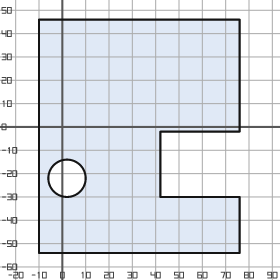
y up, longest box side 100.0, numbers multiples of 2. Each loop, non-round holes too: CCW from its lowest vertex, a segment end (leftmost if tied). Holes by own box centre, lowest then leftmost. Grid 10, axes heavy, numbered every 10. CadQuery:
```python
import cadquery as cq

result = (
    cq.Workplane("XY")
    .moveTo(-10.0, -54.0)
    .lineTo(76.0, -54.0)
    .lineTo(76.0, -30.0)
    .lineTo(42.0, -30.0)
    .lineTo(42.0, -2.0)
    .lineTo(76.0, -2.0)
    .lineTo(76.0, 46.0)
    .lineTo(-10.0, 46.0)
    .close()
    .moveTo(2.0, -22.0)
    .circle(8.0)
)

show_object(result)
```